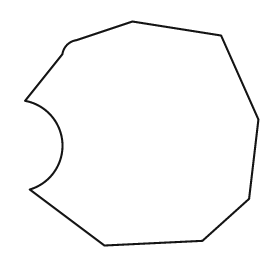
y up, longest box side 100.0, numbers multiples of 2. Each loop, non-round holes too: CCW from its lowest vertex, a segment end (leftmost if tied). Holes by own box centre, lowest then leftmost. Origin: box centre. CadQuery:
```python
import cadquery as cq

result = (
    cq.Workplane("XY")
    .moveTo(-16.0, -48.0)
    .lineTo(26.0, -46.0)
    .lineTo(46.0, -28.0)
    .lineTo(50.0, 6.0)
    .lineTo(34.0, 42.0)
    .lineTo(-4.0, 48.0)
    .lineTo(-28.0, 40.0)
    .threePointArc((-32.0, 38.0), (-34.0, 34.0))
    .lineTo(-50.0, 14.0)
    .threePointArc((-34.0, -4.0), (-48.0, -24.0))
    .close()
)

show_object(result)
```